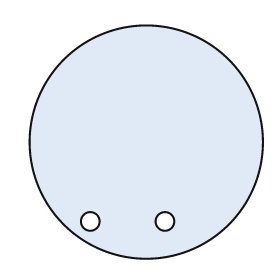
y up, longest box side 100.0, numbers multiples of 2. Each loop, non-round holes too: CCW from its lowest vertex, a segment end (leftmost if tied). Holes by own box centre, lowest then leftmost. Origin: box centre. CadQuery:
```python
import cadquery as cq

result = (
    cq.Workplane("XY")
    .moveTo(0.0, 0.0)
    .circle(50.0)
    .moveTo(-24.0, -34.0)
    .circle(4.0)
    .moveTo(8.0, -34.0)
    .circle(4.0)
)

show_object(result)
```